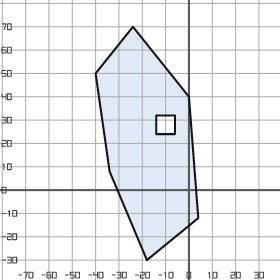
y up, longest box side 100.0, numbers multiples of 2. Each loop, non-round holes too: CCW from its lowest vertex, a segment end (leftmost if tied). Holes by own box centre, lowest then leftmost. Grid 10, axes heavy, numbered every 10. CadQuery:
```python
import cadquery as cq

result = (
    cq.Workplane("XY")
    .moveTo(-18.0, -30.0)
    .lineTo(4.0, -12.0)
    .lineTo(0.0, 40.0)
    .lineTo(-24.0, 70.0)
    .lineTo(-40.0, 50.0)
    .lineTo(-34.0, 8.0)
    .close()
    .moveTo(-14.0, 24.0)
    .lineTo(-6.0, 24.0)
    .lineTo(-6.0, 32.0)
    .lineTo(-14.0, 32.0)
    .close()
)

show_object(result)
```